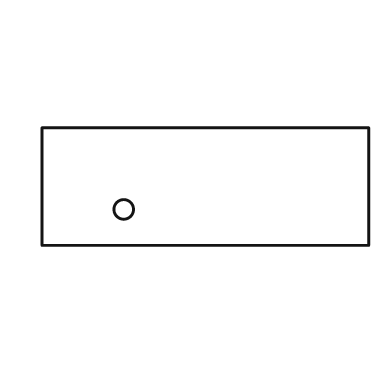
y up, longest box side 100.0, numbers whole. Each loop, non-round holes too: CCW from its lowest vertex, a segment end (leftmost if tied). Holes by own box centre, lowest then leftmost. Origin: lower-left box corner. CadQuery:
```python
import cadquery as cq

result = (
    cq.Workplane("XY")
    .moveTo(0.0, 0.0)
    .lineTo(100.0, 0.0)
    .lineTo(100.0, 36.0)
    .lineTo(0.0, 36.0)
    .close()
    .moveTo(25.0, 11.0)
    .circle(3.0)
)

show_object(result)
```